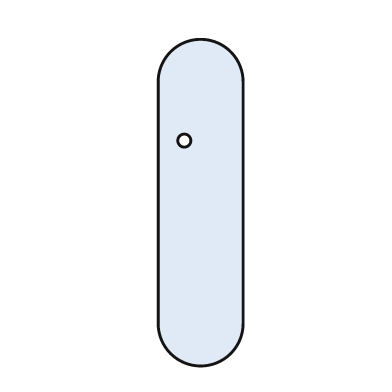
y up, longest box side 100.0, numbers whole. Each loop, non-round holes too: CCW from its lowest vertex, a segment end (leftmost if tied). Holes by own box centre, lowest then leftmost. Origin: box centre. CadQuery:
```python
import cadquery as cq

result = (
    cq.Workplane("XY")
    .moveTo(-13.0, -37.0)
    .threePointArc((0.0, -50.0), (13.0, -37.0))
    .lineTo(13.0, 37.0)
    .threePointArc((0.0, 50.0), (-13.0, 37.0))
    .close()
    .moveTo(-5.0, 19.0)
    .circle(2.0)
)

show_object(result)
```